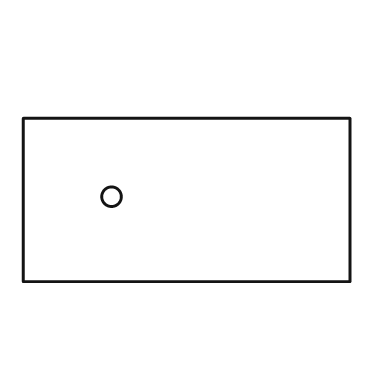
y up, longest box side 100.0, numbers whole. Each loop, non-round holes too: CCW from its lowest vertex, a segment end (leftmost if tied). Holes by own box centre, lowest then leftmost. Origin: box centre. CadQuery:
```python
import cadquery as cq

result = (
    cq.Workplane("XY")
    .moveTo(-50.0, -25.0)
    .lineTo(50.0, -25.0)
    .lineTo(50.0, 25.0)
    .lineTo(-50.0, 25.0)
    .close()
    .moveTo(-23.0, 1.0)
    .circle(3.0)
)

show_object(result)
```